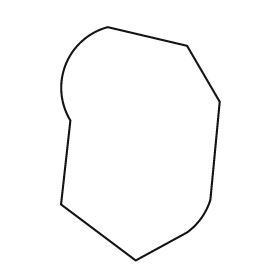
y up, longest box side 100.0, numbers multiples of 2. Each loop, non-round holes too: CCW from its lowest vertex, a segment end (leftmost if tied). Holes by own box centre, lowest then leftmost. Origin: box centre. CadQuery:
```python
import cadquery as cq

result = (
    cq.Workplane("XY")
    .moveTo(-2.0, -50.0)
    .lineTo(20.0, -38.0)
    .threePointArc((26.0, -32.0), (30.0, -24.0))
    .lineTo(34.0, 18.0)
    .lineTo(20.0, 42.0)
    .lineTo(-14.0, 50.0)
    .threePointArc((-32.0, 34.0), (-30.0, 10.0))
    .lineTo(-34.0, -26.0)
    .close()
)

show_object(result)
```